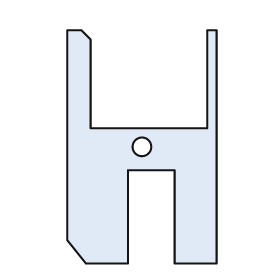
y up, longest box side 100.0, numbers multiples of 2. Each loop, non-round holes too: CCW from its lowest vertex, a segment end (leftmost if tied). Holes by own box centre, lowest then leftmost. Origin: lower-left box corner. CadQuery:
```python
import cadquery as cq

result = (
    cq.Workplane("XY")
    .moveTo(8.0, 0.0)
    .lineTo(26.0, 0.0)
    .lineTo(26.0, 40.0)
    .lineTo(46.0, 40.0)
    .lineTo(46.0, 0.0)
    .lineTo(64.0, 0.0)
    .lineTo(64.0, 100.0)
    .lineTo(60.0, 100.0)
    .lineTo(60.0, 58.0)
    .lineTo(10.0, 58.0)
    .lineTo(10.0, 96.0)
    .lineTo(6.0, 100.0)
    .lineTo(0.0, 100.0)
    .lineTo(0.0, 10.0)
    .close()
    .moveTo(32.0, 50.0)
    .circle(4.0)
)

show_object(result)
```